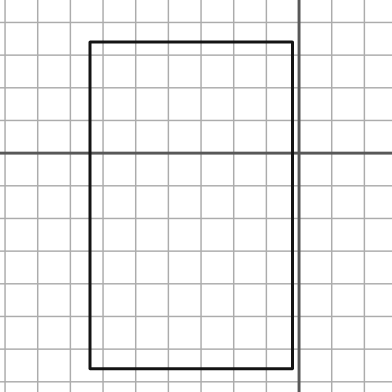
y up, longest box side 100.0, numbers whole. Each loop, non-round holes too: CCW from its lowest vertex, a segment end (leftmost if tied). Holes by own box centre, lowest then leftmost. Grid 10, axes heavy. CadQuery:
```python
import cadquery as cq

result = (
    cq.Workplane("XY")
    .moveTo(-64.0, -66.0)
    .lineTo(-2.0, -66.0)
    .lineTo(-2.0, 34.0)
    .lineTo(-64.0, 34.0)
    .close()
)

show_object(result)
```